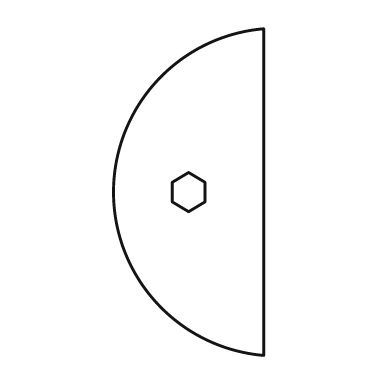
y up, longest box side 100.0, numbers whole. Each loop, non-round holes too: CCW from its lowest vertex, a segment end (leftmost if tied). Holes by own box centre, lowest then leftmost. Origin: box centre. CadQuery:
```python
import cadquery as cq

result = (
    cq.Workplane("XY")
    .moveTo(23.0, -50.0)
    .lineTo(23.0, 50.0)
    .threePointArc((-23.0, 0.0), (23.0, -50.0))
    .close()
    .moveTo(0.0, -6.0)
    .lineTo(5.0, -3.0)
    .lineTo(5.0, 3.0)
    .lineTo(0.0, 6.0)
    .lineTo(-5.0, 3.0)
    .lineTo(-5.0, -3.0)
    .close()
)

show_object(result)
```